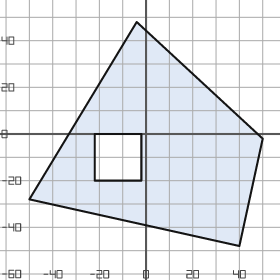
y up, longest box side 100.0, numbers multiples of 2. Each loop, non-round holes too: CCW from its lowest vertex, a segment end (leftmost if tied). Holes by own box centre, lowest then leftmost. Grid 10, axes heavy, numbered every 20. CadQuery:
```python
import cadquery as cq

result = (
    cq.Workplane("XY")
    .moveTo(40.0, -48.0)
    .lineTo(50.0, -2.0)
    .lineTo(-4.0, 48.0)
    .lineTo(-50.0, -28.0)
    .close()
    .moveTo(-22.0, -20.0)
    .lineTo(-2.0, -20.0)
    .lineTo(-2.0, 0.0)
    .lineTo(-22.0, 0.0)
    .close()
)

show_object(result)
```